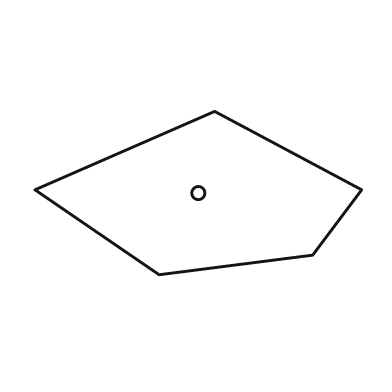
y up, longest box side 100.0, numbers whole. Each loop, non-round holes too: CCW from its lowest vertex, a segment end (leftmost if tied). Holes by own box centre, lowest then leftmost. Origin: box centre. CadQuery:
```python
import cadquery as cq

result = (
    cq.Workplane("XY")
    .moveTo(-12.0, -25.0)
    .lineTo(35.0, -19.0)
    .lineTo(50.0, 1.0)
    .lineTo(5.0, 25.0)
    .lineTo(-50.0, 1.0)
    .close()
    .moveTo(0.0, 0.0)
    .circle(2.0)
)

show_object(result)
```